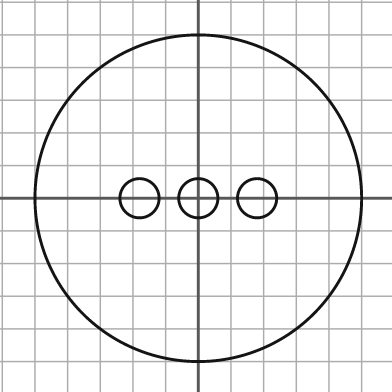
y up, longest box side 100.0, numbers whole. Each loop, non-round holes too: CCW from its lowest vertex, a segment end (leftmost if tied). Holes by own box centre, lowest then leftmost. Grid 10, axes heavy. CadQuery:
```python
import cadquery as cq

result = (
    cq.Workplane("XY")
    .moveTo(0.0, 0.0)
    .circle(50.0)
    .moveTo(-18.0, 0.0)
    .circle(6.0)
    .moveTo(0.0, 0.0)
    .circle(6.0)
    .moveTo(18.0, 0.0)
    .circle(6.0)
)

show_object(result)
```